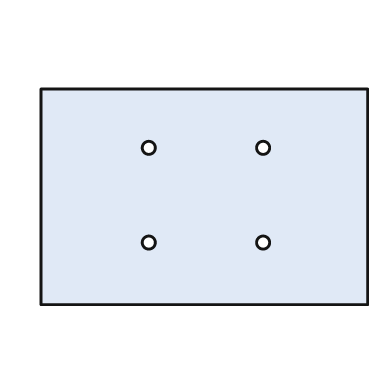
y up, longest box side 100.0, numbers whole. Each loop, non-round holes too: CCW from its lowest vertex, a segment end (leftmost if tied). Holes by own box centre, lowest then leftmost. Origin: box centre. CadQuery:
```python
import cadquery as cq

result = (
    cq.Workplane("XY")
    .moveTo(-50.0, -33.0)
    .lineTo(50.0, -33.0)
    .lineTo(50.0, 33.0)
    .lineTo(-50.0, 33.0)
    .close()
    .moveTo(-17.0, -14.0)
    .circle(2.0)
    .moveTo(18.0, -14.0)
    .circle(2.0)
    .moveTo(-17.0, 15.0)
    .circle(2.0)
    .moveTo(18.0, 15.0)
    .circle(2.0)
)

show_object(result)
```